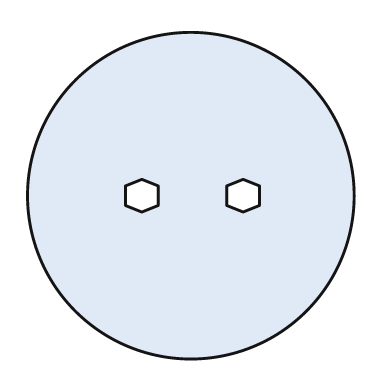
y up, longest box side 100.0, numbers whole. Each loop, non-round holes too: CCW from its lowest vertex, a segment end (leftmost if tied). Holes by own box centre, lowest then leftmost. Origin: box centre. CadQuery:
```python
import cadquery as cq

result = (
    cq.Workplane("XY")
    .moveTo(0.0, 0.0)
    .circle(50.0)
    .moveTo(-15.0, -5.0)
    .lineTo(-10.0, -3.0)
    .lineTo(-10.0, 3.0)
    .lineTo(-15.0, 5.0)
    .lineTo(-20.0, 3.0)
    .lineTo(-20.0, -3.0)
    .close()
    .moveTo(16.0, -5.0)
    .lineTo(21.0, -3.0)
    .lineTo(21.0, 3.0)
    .lineTo(16.0, 5.0)
    .lineTo(11.0, 3.0)
    .lineTo(11.0, -3.0)
    .close()
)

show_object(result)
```